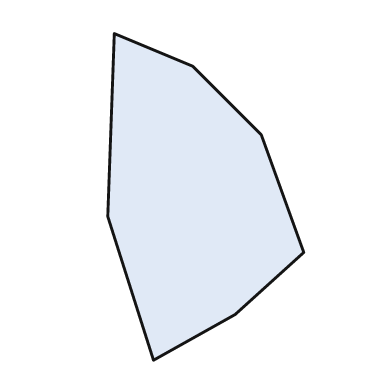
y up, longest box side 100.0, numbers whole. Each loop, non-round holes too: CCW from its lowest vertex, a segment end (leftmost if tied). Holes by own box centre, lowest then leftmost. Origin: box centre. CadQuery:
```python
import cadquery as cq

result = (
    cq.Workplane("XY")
    .moveTo(-16.0, -50.0)
    .lineTo(9.0, -36.0)
    .lineTo(30.0, -17.0)
    .lineTo(17.0, 19.0)
    .lineTo(-4.0, 40.0)
    .lineTo(-28.0, 50.0)
    .lineTo(-30.0, -6.0)
    .close()
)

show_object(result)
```